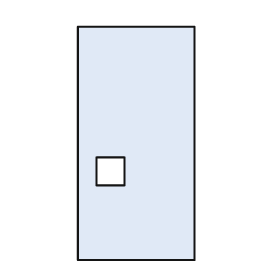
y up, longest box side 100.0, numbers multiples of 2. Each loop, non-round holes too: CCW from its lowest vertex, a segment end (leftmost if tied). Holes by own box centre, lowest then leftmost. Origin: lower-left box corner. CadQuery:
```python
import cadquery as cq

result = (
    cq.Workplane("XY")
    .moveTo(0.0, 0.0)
    .lineTo(50.0, 0.0)
    .lineTo(50.0, 100.0)
    .lineTo(0.0, 100.0)
    .close()
    .moveTo(8.0, 32.0)
    .lineTo(20.0, 32.0)
    .lineTo(20.0, 44.0)
    .lineTo(8.0, 44.0)
    .close()
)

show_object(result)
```